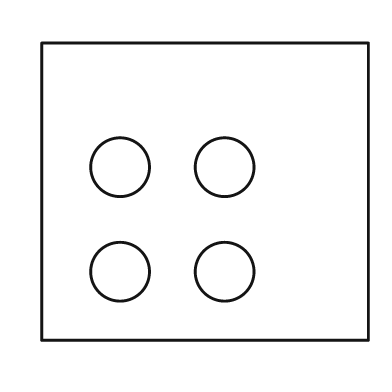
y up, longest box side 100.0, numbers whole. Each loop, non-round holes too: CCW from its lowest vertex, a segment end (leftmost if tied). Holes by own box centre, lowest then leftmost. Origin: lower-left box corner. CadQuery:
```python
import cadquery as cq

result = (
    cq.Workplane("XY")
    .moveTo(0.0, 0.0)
    .lineTo(100.0, 0.0)
    .lineTo(100.0, 91.0)
    .lineTo(0.0, 91.0)
    .close()
    .moveTo(24.0, 21.0)
    .circle(9.0)
    .moveTo(56.0, 21.0)
    .circle(9.0)
    .moveTo(24.0, 53.0)
    .circle(9.0)
    .moveTo(56.0, 53.0)
    .circle(9.0)
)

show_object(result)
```